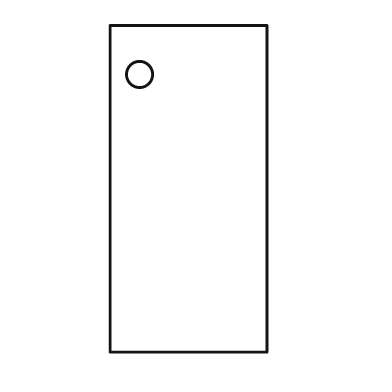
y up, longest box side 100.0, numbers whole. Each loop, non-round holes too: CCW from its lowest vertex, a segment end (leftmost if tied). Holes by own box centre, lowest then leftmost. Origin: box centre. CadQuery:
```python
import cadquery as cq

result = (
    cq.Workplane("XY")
    .moveTo(-24.0, -50.0)
    .lineTo(24.0, -50.0)
    .lineTo(24.0, 50.0)
    .lineTo(-24.0, 50.0)
    .close()
    .moveTo(-15.0, 35.0)
    .circle(4.0)
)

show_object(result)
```